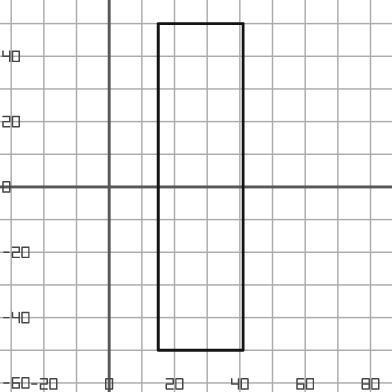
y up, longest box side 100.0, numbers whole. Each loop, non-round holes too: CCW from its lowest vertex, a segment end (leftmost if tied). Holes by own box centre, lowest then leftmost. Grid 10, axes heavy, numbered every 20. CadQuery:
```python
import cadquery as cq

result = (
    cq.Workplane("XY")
    .moveTo(15.0, -50.0)
    .lineTo(41.0, -50.0)
    .lineTo(41.0, 50.0)
    .lineTo(15.0, 50.0)
    .close()
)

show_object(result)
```